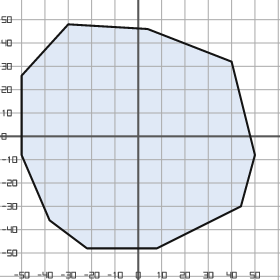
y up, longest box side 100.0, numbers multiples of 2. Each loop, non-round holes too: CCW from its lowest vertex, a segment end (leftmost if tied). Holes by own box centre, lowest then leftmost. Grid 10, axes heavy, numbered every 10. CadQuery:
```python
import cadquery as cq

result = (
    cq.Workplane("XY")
    .moveTo(-22.0, -48.0)
    .lineTo(8.0, -48.0)
    .lineTo(44.0, -30.0)
    .lineTo(50.0, -8.0)
    .lineTo(40.0, 32.0)
    .lineTo(4.0, 46.0)
    .lineTo(-30.0, 48.0)
    .lineTo(-50.0, 26.0)
    .lineTo(-50.0, -8.0)
    .lineTo(-38.0, -36.0)
    .close()
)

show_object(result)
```